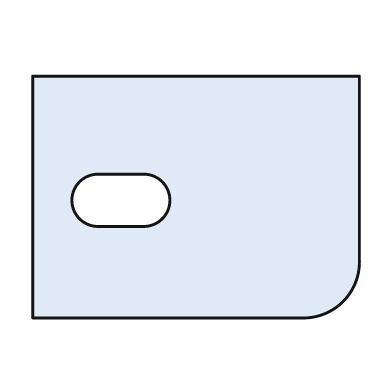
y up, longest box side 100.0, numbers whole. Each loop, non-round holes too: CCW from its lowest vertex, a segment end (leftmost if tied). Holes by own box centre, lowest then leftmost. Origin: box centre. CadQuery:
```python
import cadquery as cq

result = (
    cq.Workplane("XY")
    .moveTo(-50.0, -37.0)
    .lineTo(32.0, -37.0)
    .threePointArc((45.0, -32.0), (50.0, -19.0))
    .lineTo(50.0, 37.0)
    .lineTo(-50.0, 37.0)
    .close()
    .moveTo(-30.0, -9.0)
    .lineTo(-16.0, -9.0)
    .threePointArc((-8.0, -1.0), (-16.0, 7.0))
    .lineTo(-30.0, 7.0)
    .threePointArc((-38.0, -1.0), (-30.0, -9.0))
    .close()
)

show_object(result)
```